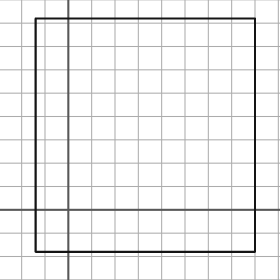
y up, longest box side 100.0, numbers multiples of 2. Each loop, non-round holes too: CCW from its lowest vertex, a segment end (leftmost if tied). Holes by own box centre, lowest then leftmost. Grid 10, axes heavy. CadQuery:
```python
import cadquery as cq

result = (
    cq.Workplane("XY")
    .moveTo(-14.0, -18.0)
    .lineTo(80.0, -18.0)
    .lineTo(80.0, 82.0)
    .lineTo(-14.0, 82.0)
    .close()
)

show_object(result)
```